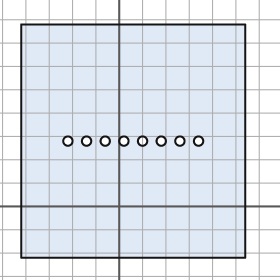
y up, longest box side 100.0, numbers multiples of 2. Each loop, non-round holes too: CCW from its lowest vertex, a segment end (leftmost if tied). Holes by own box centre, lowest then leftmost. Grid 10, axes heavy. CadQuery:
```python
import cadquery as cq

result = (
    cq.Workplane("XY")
    .moveTo(-42.0, -22.0)
    .lineTo(54.0, -22.0)
    .lineTo(54.0, 78.0)
    .lineTo(-42.0, 78.0)
    .close()
    .moveTo(-22.0, 28.0)
    .circle(2.0)
    .moveTo(-14.0, 28.0)
    .circle(2.0)
    .moveTo(-6.0, 28.0)
    .circle(2.0)
    .moveTo(2.0, 28.0)
    .circle(2.0)
    .moveTo(10.0, 28.0)
    .circle(2.0)
    .moveTo(18.0, 28.0)
    .circle(2.0)
    .moveTo(26.0, 28.0)
    .circle(2.0)
    .moveTo(34.0, 28.0)
    .circle(2.0)
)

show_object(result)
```